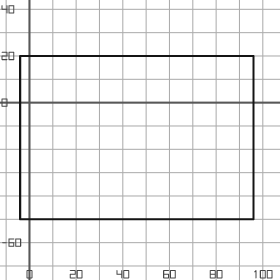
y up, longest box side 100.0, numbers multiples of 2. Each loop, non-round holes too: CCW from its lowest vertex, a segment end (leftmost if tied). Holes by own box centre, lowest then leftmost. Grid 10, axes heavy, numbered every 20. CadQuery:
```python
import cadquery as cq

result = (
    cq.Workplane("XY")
    .moveTo(-4.0, -50.0)
    .lineTo(96.0, -50.0)
    .lineTo(96.0, 20.0)
    .lineTo(-4.0, 20.0)
    .close()
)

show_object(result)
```